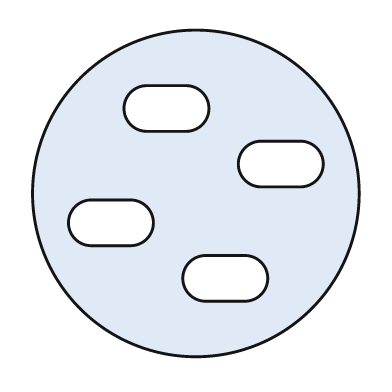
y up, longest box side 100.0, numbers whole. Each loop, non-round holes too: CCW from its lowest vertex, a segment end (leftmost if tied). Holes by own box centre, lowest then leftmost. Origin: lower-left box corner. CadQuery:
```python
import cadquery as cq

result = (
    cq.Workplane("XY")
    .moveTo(50.0, 50.0)
    .circle(50.0)
    .moveTo(53.0, 17.0)
    .lineTo(65.0, 17.0)
    .threePointArc((72.0, 24.0), (65.0, 31.0))
    .lineTo(53.0, 31.0)
    .threePointArc((46.0, 24.0), (53.0, 17.0))
    .close()
    .moveTo(18.0, 34.0)
    .lineTo(30.0, 34.0)
    .threePointArc((37.0, 41.0), (30.0, 48.0))
    .lineTo(18.0, 48.0)
    .threePointArc((11.0, 41.0), (18.0, 34.0))
    .close()
    .moveTo(70.0, 52.0)
    .lineTo(82.0, 52.0)
    .threePointArc((89.0, 59.0), (82.0, 66.0))
    .lineTo(70.0, 66.0)
    .threePointArc((63.0, 59.0), (70.0, 52.0))
    .close()
    .moveTo(35.0, 69.0)
    .lineTo(47.0, 69.0)
    .threePointArc((54.0, 76.0), (47.0, 83.0))
    .lineTo(35.0, 83.0)
    .threePointArc((28.0, 76.0), (35.0, 69.0))
    .close()
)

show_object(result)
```